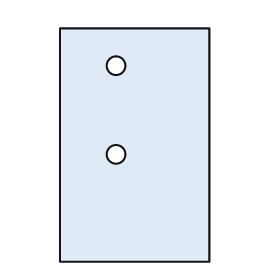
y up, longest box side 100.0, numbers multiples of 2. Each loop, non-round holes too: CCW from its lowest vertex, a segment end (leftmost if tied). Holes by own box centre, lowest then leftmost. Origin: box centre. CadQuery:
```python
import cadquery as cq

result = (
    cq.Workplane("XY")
    .moveTo(-32.0, -50.0)
    .lineTo(32.0, -50.0)
    .lineTo(32.0, 50.0)
    .lineTo(-32.0, 50.0)
    .close()
    .moveTo(-8.0, -4.0)
    .circle(4.0)
    .moveTo(-8.0, 34.0)
    .circle(4.0)
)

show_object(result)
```